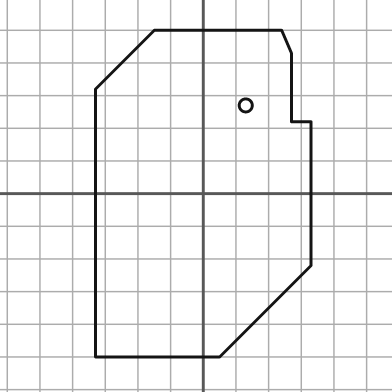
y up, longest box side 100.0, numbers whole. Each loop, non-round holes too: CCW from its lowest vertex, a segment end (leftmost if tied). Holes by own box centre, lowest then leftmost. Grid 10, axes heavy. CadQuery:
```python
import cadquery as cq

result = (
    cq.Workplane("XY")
    .moveTo(-33.0, -50.0)
    .lineTo(5.0, -50.0)
    .lineTo(33.0, -22.0)
    .lineTo(33.0, 22.0)
    .lineTo(27.0, 22.0)
    .lineTo(27.0, 43.0)
    .lineTo(24.0, 50.0)
    .lineTo(-15.0, 50.0)
    .lineTo(-33.0, 32.0)
    .close()
    .moveTo(13.0, 27.0)
    .circle(2.0)
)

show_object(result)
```